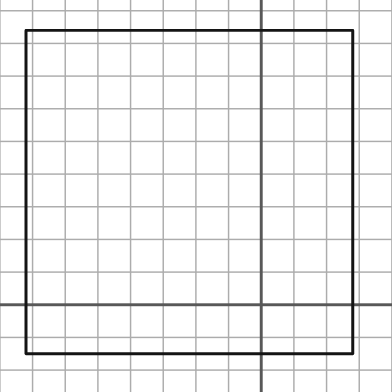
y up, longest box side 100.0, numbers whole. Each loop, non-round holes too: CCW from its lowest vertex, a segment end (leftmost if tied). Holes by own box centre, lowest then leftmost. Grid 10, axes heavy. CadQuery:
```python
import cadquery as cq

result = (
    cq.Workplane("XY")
    .moveTo(-72.0, -15.0)
    .lineTo(28.0, -15.0)
    .lineTo(28.0, 84.0)
    .lineTo(-72.0, 84.0)
    .close()
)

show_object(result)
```